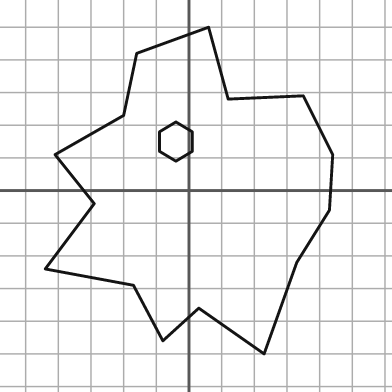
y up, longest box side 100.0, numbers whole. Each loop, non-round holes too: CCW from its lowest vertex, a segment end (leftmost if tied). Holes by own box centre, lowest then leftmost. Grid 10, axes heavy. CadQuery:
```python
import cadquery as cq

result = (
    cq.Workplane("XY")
    .moveTo(23.0, -50.0)
    .lineTo(33.0, -22.0)
    .lineTo(43.0, -6.0)
    .lineTo(44.0, 11.0)
    .lineTo(35.0, 29.0)
    .lineTo(12.0, 28.0)
    .lineTo(6.0, 50.0)
    .lineTo(-16.0, 42.0)
    .lineTo(-20.0, 23.0)
    .lineTo(-41.0, 11.0)
    .lineTo(-29.0, -4.0)
    .lineTo(-44.0, -24.0)
    .lineTo(-17.0, -29.0)
    .lineTo(-8.0, -46.0)
    .lineTo(3.0, -36.0)
    .close()
    .moveTo(-4.0, 9.0)
    .lineTo(1.0, 12.0)
    .lineTo(1.0, 18.0)
    .lineTo(-4.0, 21.0)
    .lineTo(-9.0, 18.0)
    .lineTo(-9.0, 12.0)
    .close()
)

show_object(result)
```